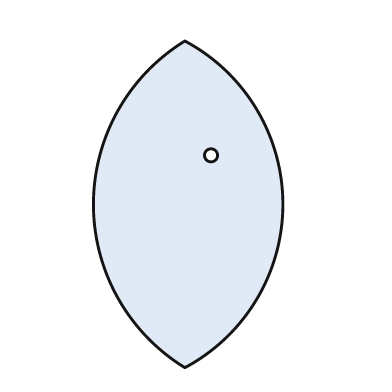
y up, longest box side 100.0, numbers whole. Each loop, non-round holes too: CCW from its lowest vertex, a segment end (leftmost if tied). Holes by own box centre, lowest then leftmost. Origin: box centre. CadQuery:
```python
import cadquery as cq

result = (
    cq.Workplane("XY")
    .moveTo(-1.0, -50.0)
    .threePointArc((29.0, 0.0), (-1.0, 50.0))
    .threePointArc((-29.0, 0.0), (-1.0, -50.0))
    .close()
    .moveTo(7.0, 15.0)
    .circle(2.0)
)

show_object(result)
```